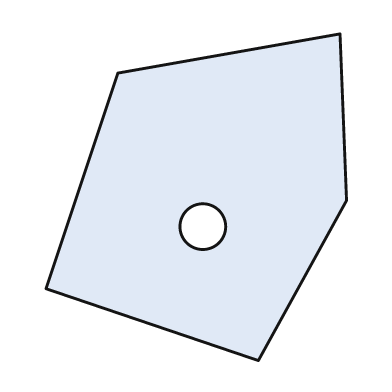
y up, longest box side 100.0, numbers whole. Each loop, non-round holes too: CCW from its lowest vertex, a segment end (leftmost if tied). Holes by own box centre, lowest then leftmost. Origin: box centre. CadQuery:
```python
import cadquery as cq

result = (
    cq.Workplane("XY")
    .moveTo(19.0, -50.0)
    .lineTo(46.0, -1.0)
    .lineTo(44.0, 50.0)
    .lineTo(-24.0, 38.0)
    .lineTo(-46.0, -28.0)
    .close()
    .moveTo(2.0, -9.0)
    .circle(7.0)
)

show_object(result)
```